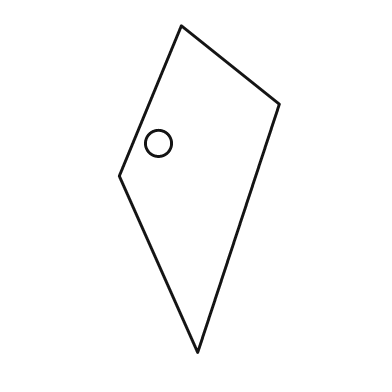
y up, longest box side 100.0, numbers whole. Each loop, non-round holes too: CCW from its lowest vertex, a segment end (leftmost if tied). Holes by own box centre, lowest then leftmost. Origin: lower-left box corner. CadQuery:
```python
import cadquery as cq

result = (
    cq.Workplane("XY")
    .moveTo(24.0, 0.0)
    .lineTo(49.0, 76.0)
    .lineTo(19.0, 100.0)
    .lineTo(0.0, 54.0)
    .close()
    .moveTo(12.0, 64.0)
    .circle(4.0)
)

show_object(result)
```